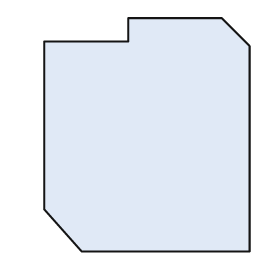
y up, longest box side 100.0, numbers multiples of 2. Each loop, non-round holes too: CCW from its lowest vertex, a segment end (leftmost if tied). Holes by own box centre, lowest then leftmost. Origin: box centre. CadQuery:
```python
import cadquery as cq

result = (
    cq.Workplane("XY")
    .moveTo(-28.0, -50.0)
    .lineTo(44.0, -50.0)
    .lineTo(44.0, 38.0)
    .lineTo(32.0, 50.0)
    .lineTo(-8.0, 50.0)
    .lineTo(-8.0, 40.0)
    .lineTo(-44.0, 40.0)
    .lineTo(-44.0, -32.0)
    .close()
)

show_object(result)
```